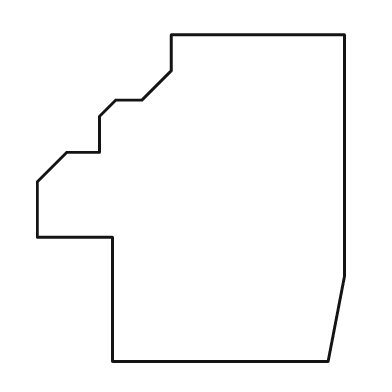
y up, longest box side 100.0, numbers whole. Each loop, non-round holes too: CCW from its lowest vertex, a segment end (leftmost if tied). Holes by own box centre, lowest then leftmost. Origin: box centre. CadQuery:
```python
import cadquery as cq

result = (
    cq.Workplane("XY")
    .moveTo(-24.0, -50.0)
    .lineTo(42.0, -50.0)
    .lineTo(47.0, -24.0)
    .lineTo(47.0, 50.0)
    .lineTo(-6.0, 50.0)
    .lineTo(-6.0, 39.0)
    .lineTo(-15.0, 30.0)
    .lineTo(-23.0, 30.0)
    .lineTo(-28.0, 25.0)
    .lineTo(-28.0, 14.0)
    .lineTo(-38.0, 14.0)
    .lineTo(-47.0, 5.0)
    .lineTo(-47.0, -12.0)
    .lineTo(-24.0, -12.0)
    .close()
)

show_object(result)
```